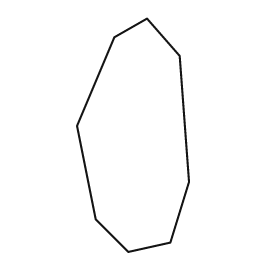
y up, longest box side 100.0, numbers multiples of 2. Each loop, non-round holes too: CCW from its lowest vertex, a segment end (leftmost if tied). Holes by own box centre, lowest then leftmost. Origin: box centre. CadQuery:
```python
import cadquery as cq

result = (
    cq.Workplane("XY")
    .moveTo(-2.0, -50.0)
    .lineTo(16.0, -46.0)
    .lineTo(24.0, -20.0)
    .lineTo(20.0, 34.0)
    .lineTo(6.0, 50.0)
    .lineTo(-8.0, 42.0)
    .lineTo(-24.0, 4.0)
    .lineTo(-16.0, -36.0)
    .close()
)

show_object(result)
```